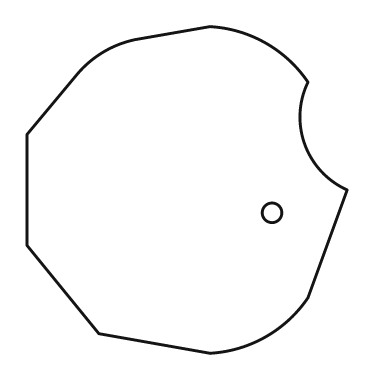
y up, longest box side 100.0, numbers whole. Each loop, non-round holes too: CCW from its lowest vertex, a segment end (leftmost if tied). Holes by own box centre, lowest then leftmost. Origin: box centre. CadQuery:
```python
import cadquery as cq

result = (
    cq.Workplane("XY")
    .moveTo(7.0, -50.0)
    .threePointArc((24.0, -45.0), (37.0, -33.0))
    .lineTo(49.0, 0.0)
    .threePointArc((36.0, 14.0), (37.0, 33.0))
    .threePointArc((24.0, 45.0), (7.0, 50.0))
    .lineTo(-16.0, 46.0)
    .threePointArc((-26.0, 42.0), (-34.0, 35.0))
    .lineTo(-49.0, 17.0)
    .lineTo(-49.0, -17.0)
    .lineTo(-27.0, -44.0)
    .close()
    .moveTo(26.0, -7.0)
    .circle(3.0)
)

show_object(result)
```